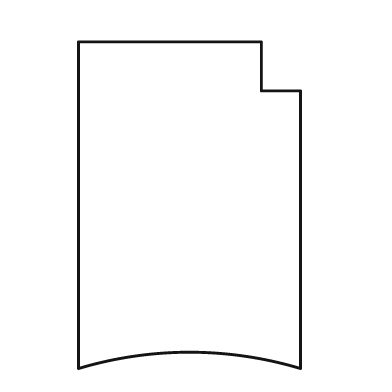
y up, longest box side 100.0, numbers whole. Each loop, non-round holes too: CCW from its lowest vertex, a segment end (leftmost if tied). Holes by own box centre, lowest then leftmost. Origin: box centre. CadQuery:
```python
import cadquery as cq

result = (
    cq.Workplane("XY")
    .moveTo(-34.0, -50.0)
    .threePointArc((0.0, -45.0), (34.0, -50.0))
    .lineTo(34.0, 35.0)
    .lineTo(22.0, 35.0)
    .lineTo(22.0, 50.0)
    .lineTo(-34.0, 50.0)
    .close()
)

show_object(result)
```